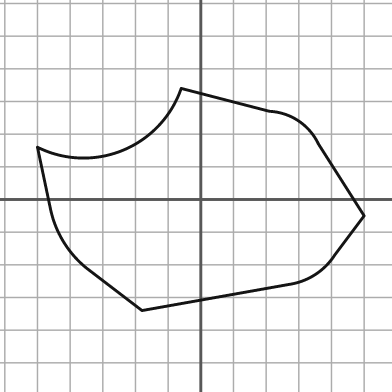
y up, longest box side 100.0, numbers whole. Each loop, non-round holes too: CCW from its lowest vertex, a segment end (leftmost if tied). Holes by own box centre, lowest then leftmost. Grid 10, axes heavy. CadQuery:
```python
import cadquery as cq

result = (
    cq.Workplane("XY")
    .moveTo(-18.0, -34.0)
    .lineTo(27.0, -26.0)
    .threePointArc((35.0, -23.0), (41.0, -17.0))
    .lineTo(50.0, -5.0)
    .lineTo(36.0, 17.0)
    .threePointArc((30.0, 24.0), (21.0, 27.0))
    .lineTo(-6.0, 34.0)
    .threePointArc((-24.0, 15.0), (-50.0, 16.0))
    .lineTo(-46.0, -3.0)
    .threePointArc((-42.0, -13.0), (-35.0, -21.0))
    .close()
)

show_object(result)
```